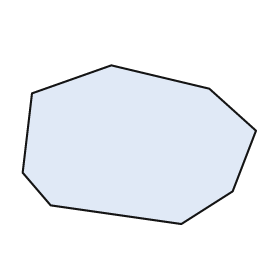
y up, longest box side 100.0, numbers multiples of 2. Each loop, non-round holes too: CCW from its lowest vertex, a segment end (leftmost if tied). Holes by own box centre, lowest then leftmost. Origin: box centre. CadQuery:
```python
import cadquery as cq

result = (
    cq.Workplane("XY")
    .moveTo(18.0, -34.0)
    .lineTo(40.0, -20.0)
    .lineTo(50.0, 6.0)
    .lineTo(30.0, 24.0)
    .lineTo(-12.0, 34.0)
    .lineTo(-46.0, 22.0)
    .lineTo(-50.0, -12.0)
    .lineTo(-38.0, -26.0)
    .close()
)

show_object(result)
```